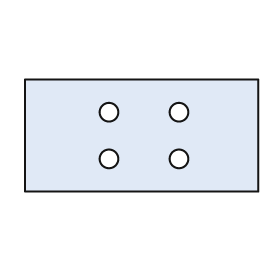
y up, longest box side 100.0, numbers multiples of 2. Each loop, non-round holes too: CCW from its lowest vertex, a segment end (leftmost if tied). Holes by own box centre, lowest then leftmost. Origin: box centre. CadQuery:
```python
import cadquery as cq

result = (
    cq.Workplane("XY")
    .moveTo(-50.0, -24.0)
    .lineTo(50.0, -24.0)
    .lineTo(50.0, 24.0)
    .lineTo(-50.0, 24.0)
    .close()
    .moveTo(-14.0, -10.0)
    .circle(4.0)
    .moveTo(16.0, -10.0)
    .circle(4.0)
    .moveTo(-14.0, 10.0)
    .circle(4.0)
    .moveTo(16.0, 10.0)
    .circle(4.0)
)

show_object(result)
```